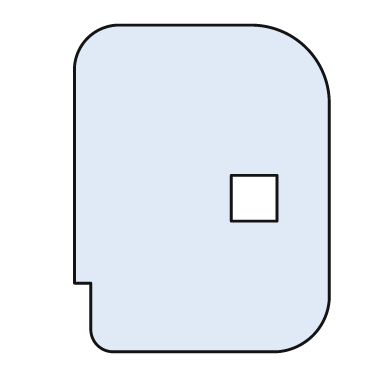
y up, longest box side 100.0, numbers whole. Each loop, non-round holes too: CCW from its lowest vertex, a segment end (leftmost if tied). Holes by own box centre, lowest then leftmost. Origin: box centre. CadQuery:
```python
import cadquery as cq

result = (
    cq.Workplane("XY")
    .moveTo(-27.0, -50.0)
    .lineTo(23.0, -50.0)
    .threePointArc((34.0, -45.0), (39.0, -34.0))
    .lineTo(39.0, 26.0)
    .threePointArc((32.0, 43.0), (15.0, 50.0))
    .lineTo(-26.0, 50.0)
    .threePointArc((-35.0, 46.0), (-39.0, 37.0))
    .lineTo(-39.0, -29.0)
    .lineTo(-34.0, -29.0)
    .lineTo(-34.0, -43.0)
    .threePointArc((-32.0, -48.0), (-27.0, -50.0))
    .close()
    .moveTo(9.0, -10.0)
    .lineTo(23.0, -10.0)
    .lineTo(23.0, 4.0)
    .lineTo(9.0, 4.0)
    .close()
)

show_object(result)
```